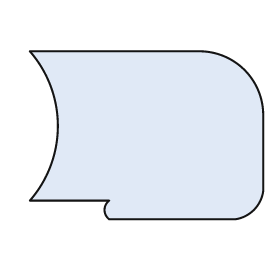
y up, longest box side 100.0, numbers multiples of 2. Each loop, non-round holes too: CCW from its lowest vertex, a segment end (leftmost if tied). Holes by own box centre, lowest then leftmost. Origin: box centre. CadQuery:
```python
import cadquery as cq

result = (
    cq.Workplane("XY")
    .moveTo(-16.0, -36.0)
    .lineTo(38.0, -36.0)
    .threePointArc((46.0, -32.0), (50.0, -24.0))
    .lineTo(50.0, 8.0)
    .threePointArc((42.0, 28.0), (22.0, 36.0))
    .lineTo(-50.0, 36.0)
    .threePointArc((-38.0, 4.0), (-50.0, -28.0))
    .lineTo(-16.0, -28.0)
    .threePointArc((-18.0, -32.0), (-16.0, -36.0))
    .close()
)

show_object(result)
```